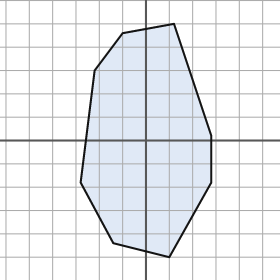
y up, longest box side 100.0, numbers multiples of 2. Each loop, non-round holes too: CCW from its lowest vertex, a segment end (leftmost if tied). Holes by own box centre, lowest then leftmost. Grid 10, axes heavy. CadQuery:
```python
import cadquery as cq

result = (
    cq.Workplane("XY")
    .moveTo(10.0, -50.0)
    .lineTo(28.0, -18.0)
    .lineTo(28.0, 2.0)
    .lineTo(12.0, 50.0)
    .lineTo(-10.0, 46.0)
    .lineTo(-22.0, 30.0)
    .lineTo(-28.0, -18.0)
    .lineTo(-14.0, -44.0)
    .close()
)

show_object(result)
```